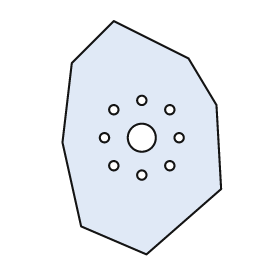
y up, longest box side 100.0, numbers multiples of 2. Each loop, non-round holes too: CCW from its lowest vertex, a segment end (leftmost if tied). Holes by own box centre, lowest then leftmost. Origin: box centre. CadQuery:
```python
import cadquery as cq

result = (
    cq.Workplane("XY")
    .moveTo(2.0, -50.0)
    .lineTo(34.0, -22.0)
    .lineTo(32.0, 14.0)
    .lineTo(20.0, 34.0)
    .lineTo(-12.0, 50.0)
    .lineTo(-30.0, 32.0)
    .lineTo(-34.0, -2.0)
    .lineTo(-26.0, -38.0)
    .close()
    .moveTo(0.0, -16.0)
    .circle(2.0)
    .moveTo(-12.0, -12.0)
    .circle(2.0)
    .moveTo(12.0, -12.0)
    .circle(2.0)
    .moveTo(-16.0, 0.0)
    .circle(2.0)
    .moveTo(0.0, 0.0)
    .circle(6.0)
    .moveTo(16.0, 0.0)
    .circle(2.0)
    .moveTo(-12.0, 12.0)
    .circle(2.0)
    .moveTo(12.0, 12.0)
    .circle(2.0)
    .moveTo(0.0, 16.0)
    .circle(2.0)
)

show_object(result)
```